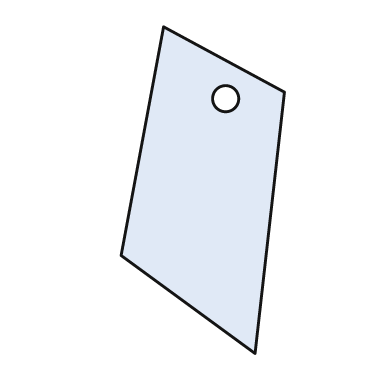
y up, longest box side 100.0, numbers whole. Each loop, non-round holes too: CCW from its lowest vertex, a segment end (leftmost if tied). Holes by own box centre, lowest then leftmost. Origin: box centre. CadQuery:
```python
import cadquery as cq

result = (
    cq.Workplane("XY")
    .moveTo(16.0, -50.0)
    .lineTo(25.0, 30.0)
    .lineTo(-12.0, 50.0)
    .lineTo(-25.0, -20.0)
    .close()
    .moveTo(7.0, 28.0)
    .circle(4.0)
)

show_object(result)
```